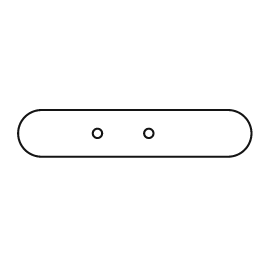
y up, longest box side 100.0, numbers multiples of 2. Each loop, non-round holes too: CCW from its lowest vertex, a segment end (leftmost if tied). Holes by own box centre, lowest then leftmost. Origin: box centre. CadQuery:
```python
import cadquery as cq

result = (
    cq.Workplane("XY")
    .moveTo(-40.0, -10.0)
    .lineTo(40.0, -10.0)
    .threePointArc((50.0, 0.0), (40.0, 10.0))
    .lineTo(-40.0, 10.0)
    .threePointArc((-50.0, 0.0), (-40.0, -10.0))
    .close()
    .moveTo(-16.0, 0.0)
    .circle(2.0)
    .moveTo(6.0, 0.0)
    .circle(2.0)
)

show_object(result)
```